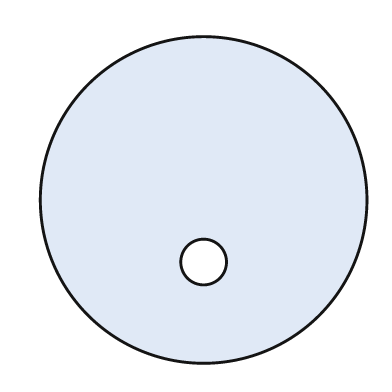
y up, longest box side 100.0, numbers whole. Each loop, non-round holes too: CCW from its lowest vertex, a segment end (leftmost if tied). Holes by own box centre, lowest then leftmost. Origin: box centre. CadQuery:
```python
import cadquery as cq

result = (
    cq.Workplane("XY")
    .moveTo(0.0, 0.0)
    .circle(50.0)
    .moveTo(0.0, -19.0)
    .circle(7.0)
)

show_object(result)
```